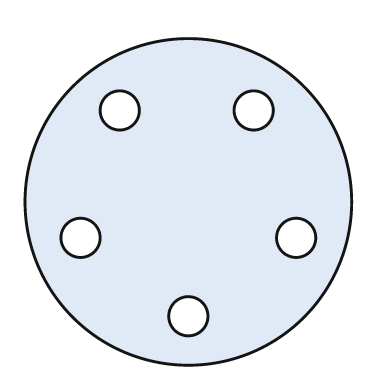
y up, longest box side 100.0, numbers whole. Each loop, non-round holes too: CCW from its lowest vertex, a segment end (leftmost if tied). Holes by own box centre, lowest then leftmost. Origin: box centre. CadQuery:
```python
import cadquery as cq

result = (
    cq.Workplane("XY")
    .moveTo(0.0, 0.0)
    .circle(50.0)
    .moveTo(0.0, -35.0)
    .circle(6.0)
    .moveTo(-33.0, -11.0)
    .circle(6.0)
    .moveTo(33.0, -11.0)
    .circle(6.0)
    .moveTo(-21.0, 28.0)
    .circle(6.0)
    .moveTo(20.0, 28.0)
    .circle(6.0)
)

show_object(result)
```